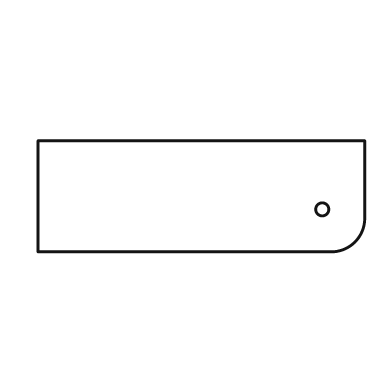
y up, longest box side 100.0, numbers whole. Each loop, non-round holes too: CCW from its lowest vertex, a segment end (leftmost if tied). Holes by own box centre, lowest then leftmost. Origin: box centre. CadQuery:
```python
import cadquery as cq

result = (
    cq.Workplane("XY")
    .moveTo(-50.0, -17.0)
    .lineTo(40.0, -17.0)
    .threePointArc((47.0, -14.0), (50.0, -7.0))
    .lineTo(50.0, 17.0)
    .lineTo(-50.0, 17.0)
    .close()
    .moveTo(37.0, -4.0)
    .circle(2.0)
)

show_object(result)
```